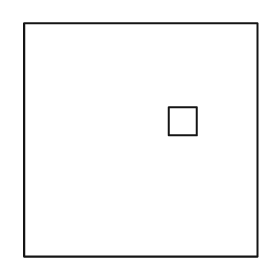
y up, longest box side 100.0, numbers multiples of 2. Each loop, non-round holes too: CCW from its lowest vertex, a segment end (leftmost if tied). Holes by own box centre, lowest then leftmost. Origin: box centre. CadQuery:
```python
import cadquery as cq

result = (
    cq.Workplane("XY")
    .moveTo(-50.0, -50.0)
    .lineTo(50.0, -50.0)
    .lineTo(50.0, 50.0)
    .lineTo(-50.0, 50.0)
    .close()
    .moveTo(12.0, 2.0)
    .lineTo(24.0, 2.0)
    .lineTo(24.0, 14.0)
    .lineTo(12.0, 14.0)
    .close()
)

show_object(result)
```